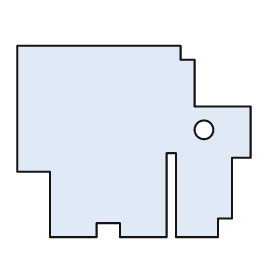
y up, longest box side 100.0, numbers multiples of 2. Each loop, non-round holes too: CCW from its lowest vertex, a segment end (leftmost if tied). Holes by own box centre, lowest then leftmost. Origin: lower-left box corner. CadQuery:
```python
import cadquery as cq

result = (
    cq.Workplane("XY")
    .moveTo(14.0, 0.0)
    .lineTo(34.0, 0.0)
    .lineTo(34.0, 6.0)
    .lineTo(44.0, 6.0)
    .lineTo(44.0, 0.0)
    .lineTo(64.0, 0.0)
    .lineTo(64.0, 36.0)
    .lineTo(68.0, 36.0)
    .lineTo(68.0, 0.0)
    .lineTo(86.0, 0.0)
    .lineTo(86.0, 8.0)
    .lineTo(92.0, 8.0)
    .lineTo(92.0, 34.0)
    .lineTo(100.0, 34.0)
    .lineTo(100.0, 56.0)
    .lineTo(76.0, 56.0)
    .lineTo(76.0, 76.0)
    .lineTo(70.0, 76.0)
    .lineTo(70.0, 82.0)
    .lineTo(0.0, 82.0)
    .lineTo(0.0, 28.0)
    .lineTo(14.0, 28.0)
    .close()
    .moveTo(80.0, 46.0)
    .circle(4.0)
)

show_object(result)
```